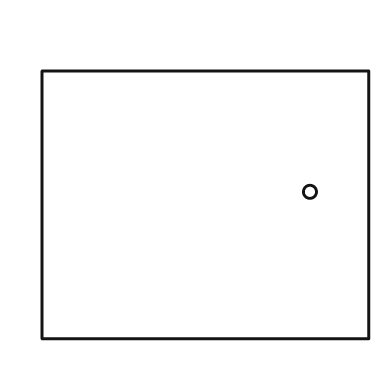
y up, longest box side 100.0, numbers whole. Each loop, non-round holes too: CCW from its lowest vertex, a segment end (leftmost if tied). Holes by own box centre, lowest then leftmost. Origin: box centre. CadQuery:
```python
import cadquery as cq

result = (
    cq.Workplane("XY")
    .moveTo(-50.0, -41.0)
    .lineTo(50.0, -41.0)
    .lineTo(50.0, 41.0)
    .lineTo(-50.0, 41.0)
    .close()
    .moveTo(32.0, 4.0)
    .circle(2.0)
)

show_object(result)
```